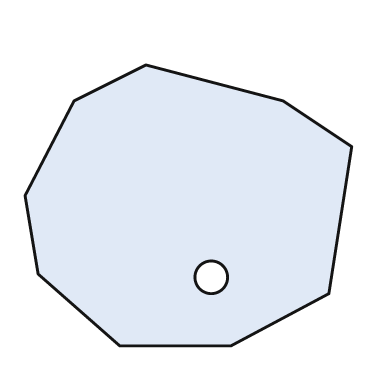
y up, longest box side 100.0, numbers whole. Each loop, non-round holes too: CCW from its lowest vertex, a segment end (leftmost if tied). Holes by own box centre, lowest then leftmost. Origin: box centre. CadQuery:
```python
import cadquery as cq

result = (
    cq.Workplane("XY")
    .moveTo(-21.0, -43.0)
    .lineTo(13.0, -43.0)
    .lineTo(43.0, -27.0)
    .lineTo(50.0, 18.0)
    .lineTo(29.0, 32.0)
    .lineTo(-13.0, 43.0)
    .lineTo(-35.0, 32.0)
    .lineTo(-50.0, 3.0)
    .lineTo(-46.0, -21.0)
    .close()
    .moveTo(7.0, -22.0)
    .circle(5.0)
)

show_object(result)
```